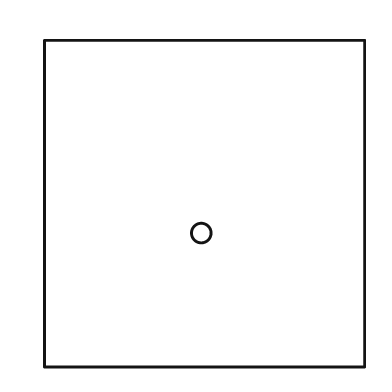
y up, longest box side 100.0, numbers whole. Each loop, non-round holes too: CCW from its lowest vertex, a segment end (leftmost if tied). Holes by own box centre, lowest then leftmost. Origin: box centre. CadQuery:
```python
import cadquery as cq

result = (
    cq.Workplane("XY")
    .moveTo(-49.0, -50.0)
    .lineTo(49.0, -50.0)
    .lineTo(49.0, 50.0)
    .lineTo(-49.0, 50.0)
    .close()
    .moveTo(-1.0, -9.0)
    .circle(3.0)
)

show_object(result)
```